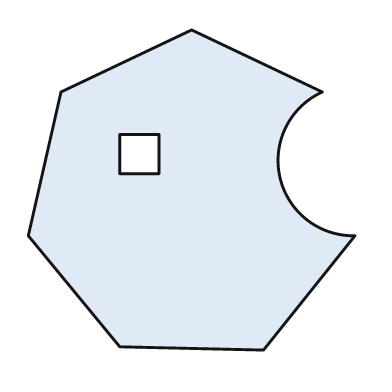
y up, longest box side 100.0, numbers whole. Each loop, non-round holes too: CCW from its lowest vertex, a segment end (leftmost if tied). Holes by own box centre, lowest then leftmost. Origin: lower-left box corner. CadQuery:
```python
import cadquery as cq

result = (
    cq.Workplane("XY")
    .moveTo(72.0, 0.0)
    .lineTo(100.0, 35.0)
    .threePointArc((77.0, 53.0), (90.0, 79.0))
    .lineTo(50.0, 98.0)
    .lineTo(10.0, 79.0)
    .lineTo(0.0, 35.0)
    .lineTo(28.0, 1.0)
    .close()
    .moveTo(28.0, 54.0)
    .lineTo(40.0, 54.0)
    .lineTo(40.0, 66.0)
    .lineTo(28.0, 66.0)
    .close()
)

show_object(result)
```